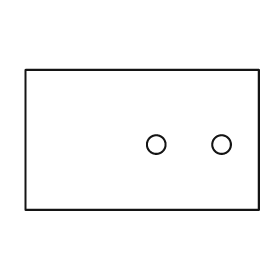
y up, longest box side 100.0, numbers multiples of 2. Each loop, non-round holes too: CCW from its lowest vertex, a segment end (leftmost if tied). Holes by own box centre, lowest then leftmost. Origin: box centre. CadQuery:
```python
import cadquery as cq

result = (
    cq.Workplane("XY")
    .moveTo(-50.0, -30.0)
    .lineTo(50.0, -30.0)
    .lineTo(50.0, 30.0)
    .lineTo(-50.0, 30.0)
    .close()
    .moveTo(6.0, -2.0)
    .circle(4.0)
    .moveTo(34.0, -2.0)
    .circle(4.0)
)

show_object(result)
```